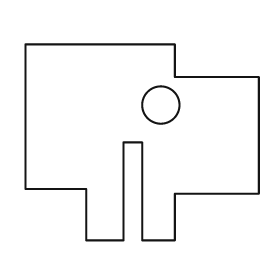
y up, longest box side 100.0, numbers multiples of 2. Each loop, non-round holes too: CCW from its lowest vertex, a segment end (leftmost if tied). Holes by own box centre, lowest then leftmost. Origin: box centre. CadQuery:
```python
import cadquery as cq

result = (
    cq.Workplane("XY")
    .moveTo(-24.0, -42.0)
    .lineTo(-8.0, -42.0)
    .lineTo(-8.0, 0.0)
    .lineTo(0.0, 0.0)
    .lineTo(0.0, -42.0)
    .lineTo(14.0, -42.0)
    .lineTo(14.0, -22.0)
    .lineTo(50.0, -22.0)
    .lineTo(50.0, 28.0)
    .lineTo(14.0, 28.0)
    .lineTo(14.0, 42.0)
    .lineTo(-50.0, 42.0)
    .lineTo(-50.0, -20.0)
    .lineTo(-24.0, -20.0)
    .close()
    .moveTo(8.0, 16.0)
    .circle(8.0)
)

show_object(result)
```